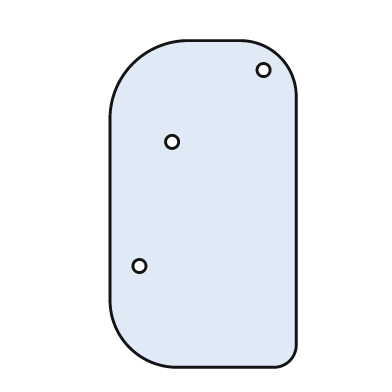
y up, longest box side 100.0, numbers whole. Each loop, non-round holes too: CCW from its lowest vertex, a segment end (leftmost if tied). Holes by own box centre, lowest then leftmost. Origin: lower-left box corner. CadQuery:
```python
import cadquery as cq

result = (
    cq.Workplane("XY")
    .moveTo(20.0, 0.0)
    .lineTo(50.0, 0.0)
    .threePointArc((55.0, 2.0), (57.0, 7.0))
    .lineTo(57.0, 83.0)
    .threePointArc((52.0, 95.0), (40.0, 100.0))
    .lineTo(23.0, 100.0)
    .threePointArc((7.0, 93.0), (0.0, 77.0))
    .lineTo(0.0, 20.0)
    .threePointArc((6.0, 6.0), (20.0, 0.0))
    .close()
    .moveTo(9.0, 31.0)
    .circle(2.0)
    .moveTo(19.0, 69.0)
    .circle(2.0)
    .moveTo(47.0, 91.0)
    .circle(2.0)
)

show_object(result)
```